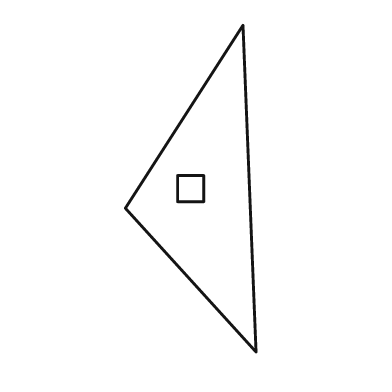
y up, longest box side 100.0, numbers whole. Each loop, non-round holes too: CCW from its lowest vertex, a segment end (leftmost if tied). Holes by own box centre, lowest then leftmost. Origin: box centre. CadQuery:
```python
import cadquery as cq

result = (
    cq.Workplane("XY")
    .moveTo(20.0, -50.0)
    .lineTo(16.0, 50.0)
    .lineTo(-20.0, -6.0)
    .close()
    .moveTo(-4.0, -4.0)
    .lineTo(4.0, -4.0)
    .lineTo(4.0, 4.0)
    .lineTo(-4.0, 4.0)
    .close()
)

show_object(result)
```